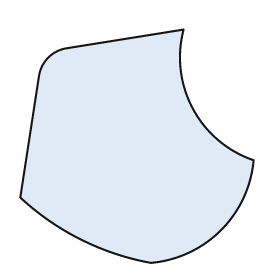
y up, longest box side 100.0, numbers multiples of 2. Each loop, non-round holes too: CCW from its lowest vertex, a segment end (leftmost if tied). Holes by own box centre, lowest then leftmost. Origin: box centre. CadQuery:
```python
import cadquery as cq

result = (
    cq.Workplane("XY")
    .moveTo(6.0, -50.0)
    .threePointArc((36.0, -36.0), (50.0, -6.0))
    .threePointArc((24.0, 16.0), (20.0, 50.0))
    .lineTo(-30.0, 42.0)
    .threePointArc((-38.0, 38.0), (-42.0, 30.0))
    .lineTo(-50.0, -22.0)
    .threePointArc((-24.0, -40.0), (6.0, -50.0))
    .close()
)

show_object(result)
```